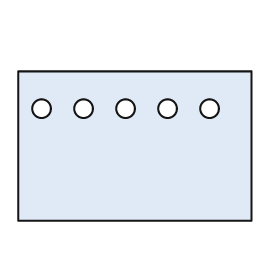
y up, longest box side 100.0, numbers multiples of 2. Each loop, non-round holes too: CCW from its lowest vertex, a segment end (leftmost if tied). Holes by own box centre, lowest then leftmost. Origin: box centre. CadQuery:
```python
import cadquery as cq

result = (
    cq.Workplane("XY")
    .moveTo(-50.0, -32.0)
    .lineTo(50.0, -32.0)
    .lineTo(50.0, 32.0)
    .lineTo(-50.0, 32.0)
    .close()
    .moveTo(-40.0, 16.0)
    .circle(4.0)
    .moveTo(-22.0, 16.0)
    .circle(4.0)
    .moveTo(-4.0, 16.0)
    .circle(4.0)
    .moveTo(14.0, 16.0)
    .circle(4.0)
    .moveTo(32.0, 16.0)
    .circle(4.0)
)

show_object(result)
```